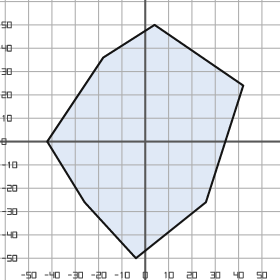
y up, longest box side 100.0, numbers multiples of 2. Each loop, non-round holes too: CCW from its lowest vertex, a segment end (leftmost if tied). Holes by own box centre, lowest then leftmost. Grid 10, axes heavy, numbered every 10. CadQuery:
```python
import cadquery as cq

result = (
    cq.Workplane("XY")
    .moveTo(-4.0, -50.0)
    .lineTo(26.0, -26.0)
    .lineTo(42.0, 24.0)
    .lineTo(4.0, 50.0)
    .lineTo(-18.0, 36.0)
    .lineTo(-42.0, 0.0)
    .lineTo(-26.0, -26.0)
    .close()
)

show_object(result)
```